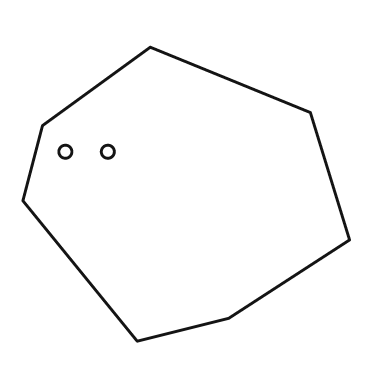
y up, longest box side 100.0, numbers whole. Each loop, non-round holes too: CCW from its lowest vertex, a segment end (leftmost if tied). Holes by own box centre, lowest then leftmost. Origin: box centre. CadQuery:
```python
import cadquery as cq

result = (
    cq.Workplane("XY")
    .moveTo(-15.0, -45.0)
    .lineTo(13.0, -38.0)
    .lineTo(50.0, -14.0)
    .lineTo(38.0, 25.0)
    .lineTo(-11.0, 45.0)
    .lineTo(-44.0, 21.0)
    .lineTo(-50.0, -2.0)
    .close()
    .moveTo(-37.0, 13.0)
    .circle(2.0)
    .moveTo(-24.0, 13.0)
    .circle(2.0)
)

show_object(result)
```